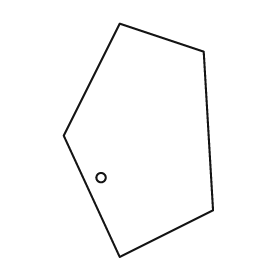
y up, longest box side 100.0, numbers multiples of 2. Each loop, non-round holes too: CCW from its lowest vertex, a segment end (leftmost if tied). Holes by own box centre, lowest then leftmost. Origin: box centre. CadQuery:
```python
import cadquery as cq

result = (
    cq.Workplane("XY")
    .moveTo(-8.0, -50.0)
    .lineTo(32.0, -30.0)
    .lineTo(28.0, 38.0)
    .lineTo(-8.0, 50.0)
    .lineTo(-32.0, 2.0)
    .close()
    .moveTo(-16.0, -16.0)
    .circle(2.0)
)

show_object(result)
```